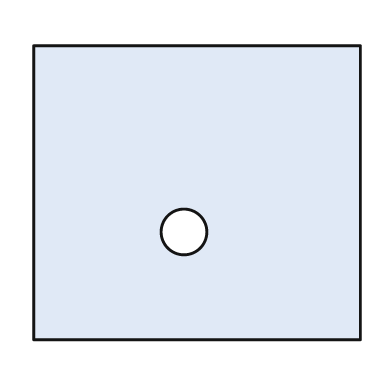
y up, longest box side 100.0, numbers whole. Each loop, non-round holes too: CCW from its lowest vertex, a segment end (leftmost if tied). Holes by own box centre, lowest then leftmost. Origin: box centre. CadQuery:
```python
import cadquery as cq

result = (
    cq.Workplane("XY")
    .moveTo(-50.0, -45.0)
    .lineTo(50.0, -45.0)
    .lineTo(50.0, 45.0)
    .lineTo(-50.0, 45.0)
    .close()
    .moveTo(-4.0, -12.0)
    .circle(7.0)
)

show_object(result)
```